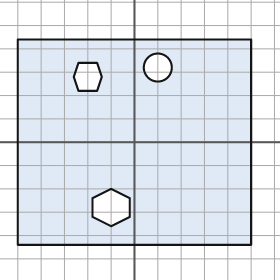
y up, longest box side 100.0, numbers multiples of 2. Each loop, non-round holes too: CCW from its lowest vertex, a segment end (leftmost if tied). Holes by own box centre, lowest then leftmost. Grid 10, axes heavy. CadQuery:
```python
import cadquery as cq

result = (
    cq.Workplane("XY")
    .moveTo(-50.0, -44.0)
    .lineTo(50.0, -44.0)
    .lineTo(50.0, 44.0)
    .lineTo(-50.0, 44.0)
    .close()
    .moveTo(-10.0, -36.0)
    .lineTo(-2.0, -32.0)
    .lineTo(-2.0, -24.0)
    .lineTo(-10.0, -20.0)
    .lineTo(-18.0, -24.0)
    .lineTo(-18.0, -32.0)
    .close()
    .moveTo(-24.0, 22.0)
    .lineTo(-16.0, 22.0)
    .lineTo(-14.0, 28.0)
    .lineTo(-16.0, 34.0)
    .lineTo(-24.0, 34.0)
    .lineTo(-26.0, 28.0)
    .close()
    .moveTo(10.0, 32.0)
    .circle(6.0)
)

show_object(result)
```